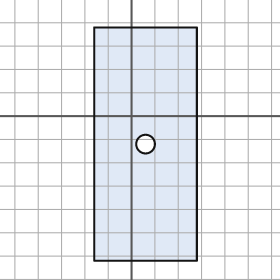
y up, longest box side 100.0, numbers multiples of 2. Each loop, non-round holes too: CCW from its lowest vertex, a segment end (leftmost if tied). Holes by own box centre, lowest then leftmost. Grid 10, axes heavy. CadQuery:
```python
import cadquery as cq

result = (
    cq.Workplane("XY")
    .moveTo(-16.0, -62.0)
    .lineTo(28.0, -62.0)
    .lineTo(28.0, 38.0)
    .lineTo(-16.0, 38.0)
    .close()
    .moveTo(6.0, -12.0)
    .circle(4.0)
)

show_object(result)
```